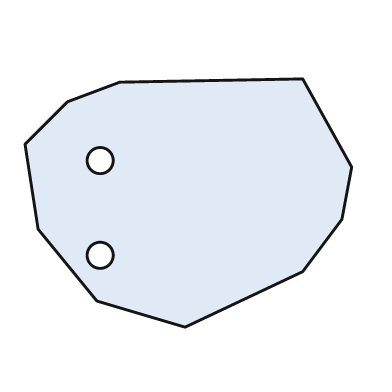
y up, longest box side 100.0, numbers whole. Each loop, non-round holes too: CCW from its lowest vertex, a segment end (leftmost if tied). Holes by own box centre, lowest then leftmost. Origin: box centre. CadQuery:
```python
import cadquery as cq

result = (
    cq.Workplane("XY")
    .moveTo(-1.0, -38.0)
    .lineTo(35.0, -21.0)
    .lineTo(47.0, -5.0)
    .lineTo(50.0, 11.0)
    .lineTo(35.0, 38.0)
    .lineTo(-21.0, 37.0)
    .lineTo(-37.0, 31.0)
    .lineTo(-50.0, 18.0)
    .lineTo(-46.0, -8.0)
    .lineTo(-28.0, -30.0)
    .close()
    .moveTo(-27.0, -16.0)
    .circle(4.0)
    .moveTo(-27.0, 13.0)
    .circle(4.0)
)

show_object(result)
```